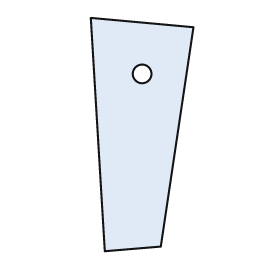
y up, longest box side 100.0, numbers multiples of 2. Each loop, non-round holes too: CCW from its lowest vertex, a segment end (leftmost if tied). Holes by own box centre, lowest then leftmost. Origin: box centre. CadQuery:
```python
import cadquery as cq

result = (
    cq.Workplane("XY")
    .moveTo(-16.0, -50.0)
    .lineTo(8.0, -48.0)
    .lineTo(22.0, 46.0)
    .lineTo(-22.0, 50.0)
    .close()
    .moveTo(0.0, 26.0)
    .circle(4.0)
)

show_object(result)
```